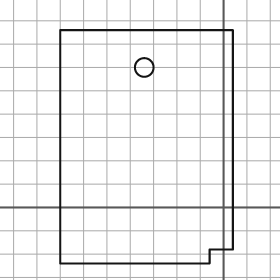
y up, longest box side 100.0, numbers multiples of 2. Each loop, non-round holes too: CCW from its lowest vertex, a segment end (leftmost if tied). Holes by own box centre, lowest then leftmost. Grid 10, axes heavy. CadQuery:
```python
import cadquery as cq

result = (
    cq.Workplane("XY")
    .moveTo(-70.0, -24.0)
    .lineTo(-6.0, -24.0)
    .lineTo(-6.0, -18.0)
    .lineTo(4.0, -18.0)
    .lineTo(4.0, 76.0)
    .lineTo(-70.0, 76.0)
    .close()
    .moveTo(-34.0, 60.0)
    .circle(4.0)
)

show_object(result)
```